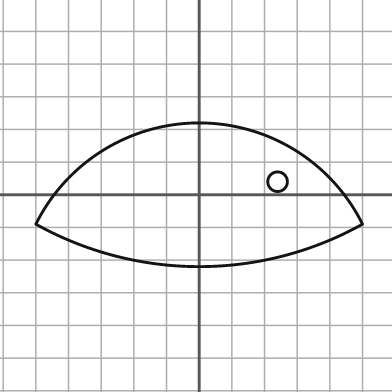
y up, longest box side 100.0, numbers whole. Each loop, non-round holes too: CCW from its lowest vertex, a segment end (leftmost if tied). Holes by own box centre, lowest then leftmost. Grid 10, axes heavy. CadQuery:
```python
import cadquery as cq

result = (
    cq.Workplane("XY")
    .moveTo(-50.0, -9.0)
    .threePointArc((0.0, -22.0), (50.0, -9.0))
    .threePointArc((0.0, 22.0), (-50.0, -9.0))
    .close()
    .moveTo(24.0, 4.0)
    .circle(3.0)
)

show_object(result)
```